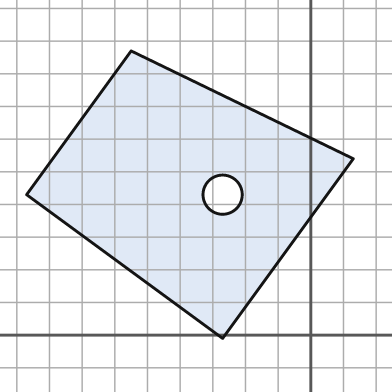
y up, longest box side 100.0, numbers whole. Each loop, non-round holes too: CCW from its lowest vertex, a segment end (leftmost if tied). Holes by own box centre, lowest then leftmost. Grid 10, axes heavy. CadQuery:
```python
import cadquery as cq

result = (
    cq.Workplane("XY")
    .moveTo(-27.0, -1.0)
    .lineTo(13.0, 54.0)
    .lineTo(-55.0, 87.0)
    .lineTo(-87.0, 43.0)
    .close()
    .moveTo(-27.0, 43.0)
    .circle(6.0)
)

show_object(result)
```